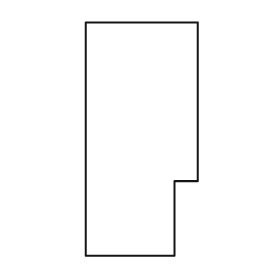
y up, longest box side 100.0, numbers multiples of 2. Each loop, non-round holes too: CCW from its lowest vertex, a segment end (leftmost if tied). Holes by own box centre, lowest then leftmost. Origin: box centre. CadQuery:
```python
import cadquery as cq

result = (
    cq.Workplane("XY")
    .moveTo(-24.0, -50.0)
    .lineTo(14.0, -50.0)
    .lineTo(14.0, -18.0)
    .lineTo(24.0, -18.0)
    .lineTo(24.0, 50.0)
    .lineTo(-24.0, 50.0)
    .close()
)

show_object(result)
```